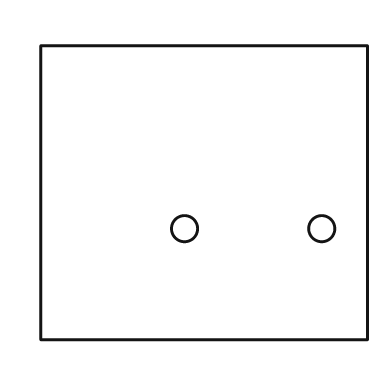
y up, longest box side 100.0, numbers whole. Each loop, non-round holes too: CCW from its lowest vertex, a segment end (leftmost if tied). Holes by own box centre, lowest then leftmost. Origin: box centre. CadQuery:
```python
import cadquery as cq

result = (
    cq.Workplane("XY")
    .moveTo(-50.0, -45.0)
    .lineTo(50.0, -45.0)
    .lineTo(50.0, 45.0)
    .lineTo(-50.0, 45.0)
    .close()
    .moveTo(-6.0, -11.0)
    .circle(4.0)
    .moveTo(36.0, -11.0)
    .circle(4.0)
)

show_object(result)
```